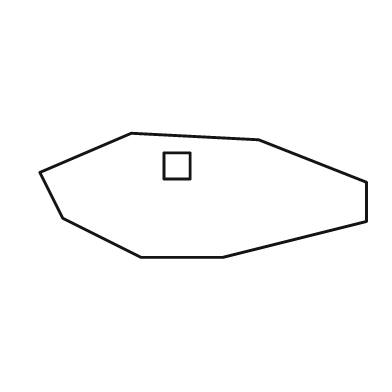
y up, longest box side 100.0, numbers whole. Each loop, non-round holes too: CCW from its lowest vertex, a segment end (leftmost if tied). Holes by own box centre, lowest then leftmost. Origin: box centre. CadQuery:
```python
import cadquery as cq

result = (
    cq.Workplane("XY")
    .moveTo(-19.0, -19.0)
    .lineTo(6.0, -19.0)
    .lineTo(50.0, -8.0)
    .lineTo(50.0, 4.0)
    .lineTo(17.0, 17.0)
    .lineTo(-22.0, 19.0)
    .lineTo(-50.0, 7.0)
    .lineTo(-43.0, -7.0)
    .close()
    .moveTo(-12.0, 5.0)
    .lineTo(-4.0, 5.0)
    .lineTo(-4.0, 13.0)
    .lineTo(-12.0, 13.0)
    .close()
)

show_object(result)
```